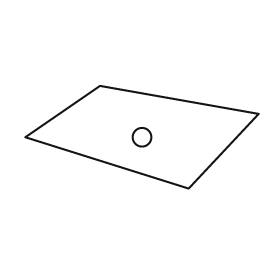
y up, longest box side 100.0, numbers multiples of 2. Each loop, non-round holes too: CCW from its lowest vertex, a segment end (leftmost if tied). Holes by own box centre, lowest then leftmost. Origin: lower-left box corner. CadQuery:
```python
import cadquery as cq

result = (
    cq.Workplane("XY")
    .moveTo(70.0, 0.0)
    .lineTo(100.0, 32.0)
    .lineTo(32.0, 44.0)
    .lineTo(0.0, 22.0)
    .close()
    .moveTo(50.0, 22.0)
    .circle(4.0)
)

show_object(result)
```